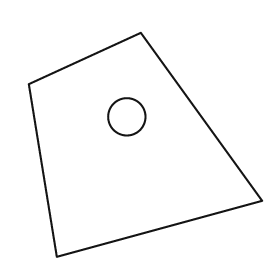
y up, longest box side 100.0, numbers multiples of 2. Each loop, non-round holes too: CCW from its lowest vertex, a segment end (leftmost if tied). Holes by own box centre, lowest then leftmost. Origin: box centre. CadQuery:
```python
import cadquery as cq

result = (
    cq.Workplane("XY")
    .moveTo(-38.0, -48.0)
    .lineTo(50.0, -24.0)
    .lineTo(-2.0, 48.0)
    .lineTo(-50.0, 26.0)
    .close()
    .moveTo(-8.0, 12.0)
    .circle(8.0)
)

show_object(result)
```